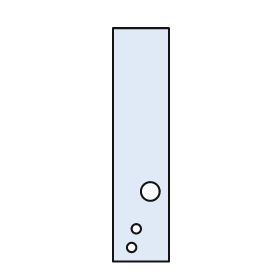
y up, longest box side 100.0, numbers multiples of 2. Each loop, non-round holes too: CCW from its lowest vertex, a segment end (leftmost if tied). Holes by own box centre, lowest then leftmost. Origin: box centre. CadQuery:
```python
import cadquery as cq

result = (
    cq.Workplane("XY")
    .moveTo(-12.0, -50.0)
    .lineTo(12.0, -50.0)
    .lineTo(12.0, 50.0)
    .lineTo(-12.0, 50.0)
    .close()
    .moveTo(-4.0, -44.0)
    .circle(2.0)
    .moveTo(-2.0, -36.0)
    .circle(2.0)
    .moveTo(4.0, -20.0)
    .circle(4.0)
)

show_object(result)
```